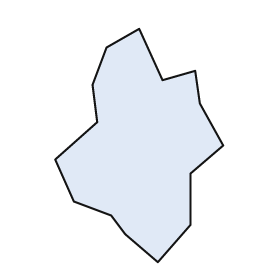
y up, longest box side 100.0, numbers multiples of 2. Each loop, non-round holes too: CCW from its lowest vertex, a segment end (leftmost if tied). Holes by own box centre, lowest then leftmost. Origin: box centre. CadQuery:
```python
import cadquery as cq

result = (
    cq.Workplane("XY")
    .moveTo(8.0, -50.0)
    .lineTo(22.0, -34.0)
    .lineTo(22.0, -12.0)
    .lineTo(36.0, 0.0)
    .lineTo(26.0, 18.0)
    .lineTo(24.0, 32.0)
    .lineTo(10.0, 28.0)
    .lineTo(0.0, 50.0)
    .lineTo(-14.0, 42.0)
    .lineTo(-20.0, 26.0)
    .lineTo(-18.0, 10.0)
    .lineTo(-36.0, -6.0)
    .lineTo(-28.0, -24.0)
    .lineTo(-12.0, -30.0)
    .lineTo(-6.0, -38.0)
    .close()
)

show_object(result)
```